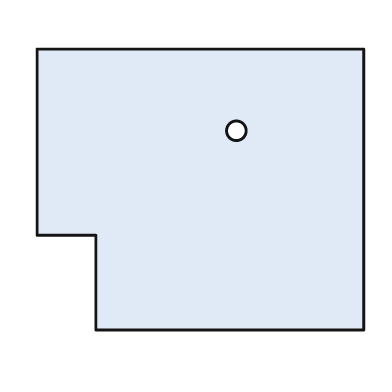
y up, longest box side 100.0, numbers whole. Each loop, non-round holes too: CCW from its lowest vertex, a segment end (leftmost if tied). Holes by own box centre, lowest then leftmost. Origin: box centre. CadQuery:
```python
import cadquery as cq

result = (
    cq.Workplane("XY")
    .moveTo(-32.0, -43.0)
    .lineTo(50.0, -43.0)
    .lineTo(50.0, 43.0)
    .lineTo(-50.0, 43.0)
    .lineTo(-50.0, -14.0)
    .lineTo(-32.0, -14.0)
    .close()
    .moveTo(11.0, 18.0)
    .circle(3.0)
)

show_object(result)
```